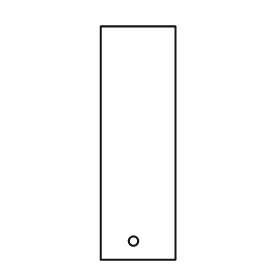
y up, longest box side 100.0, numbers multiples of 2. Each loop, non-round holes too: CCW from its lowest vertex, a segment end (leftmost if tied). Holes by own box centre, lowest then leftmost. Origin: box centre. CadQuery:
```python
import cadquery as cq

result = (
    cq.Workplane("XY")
    .moveTo(-16.0, -50.0)
    .lineTo(16.0, -50.0)
    .lineTo(16.0, 50.0)
    .lineTo(-16.0, 50.0)
    .close()
    .moveTo(-2.0, -42.0)
    .circle(2.0)
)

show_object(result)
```